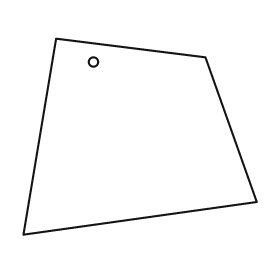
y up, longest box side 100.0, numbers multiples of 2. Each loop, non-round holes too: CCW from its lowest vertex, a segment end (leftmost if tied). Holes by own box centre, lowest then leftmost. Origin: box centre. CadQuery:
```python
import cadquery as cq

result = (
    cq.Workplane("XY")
    .moveTo(-50.0, -42.0)
    .lineTo(50.0, -28.0)
    .lineTo(28.0, 34.0)
    .lineTo(-36.0, 42.0)
    .close()
    .moveTo(-20.0, 32.0)
    .circle(2.0)
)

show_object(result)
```